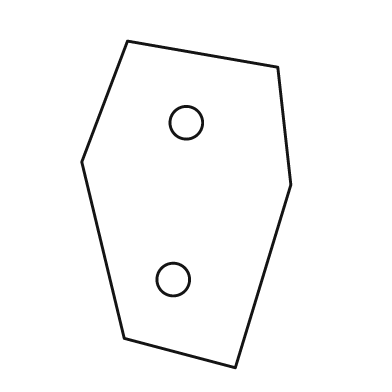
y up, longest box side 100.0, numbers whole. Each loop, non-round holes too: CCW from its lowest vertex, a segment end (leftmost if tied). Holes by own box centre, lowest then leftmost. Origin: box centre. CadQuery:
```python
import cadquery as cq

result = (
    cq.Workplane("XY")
    .moveTo(15.0, -50.0)
    .lineTo(32.0, 6.0)
    .lineTo(28.0, 42.0)
    .lineTo(-18.0, 50.0)
    .lineTo(-32.0, 13.0)
    .lineTo(-19.0, -41.0)
    .close()
    .moveTo(-4.0, -23.0)
    .circle(5.0)
    .moveTo(0.0, 25.0)
    .circle(5.0)
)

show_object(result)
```